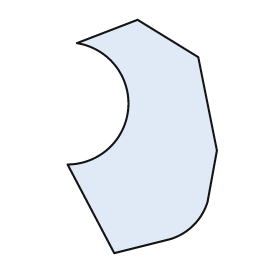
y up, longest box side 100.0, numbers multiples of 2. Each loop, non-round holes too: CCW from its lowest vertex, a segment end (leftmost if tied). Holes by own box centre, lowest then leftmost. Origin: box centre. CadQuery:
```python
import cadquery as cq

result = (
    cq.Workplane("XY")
    .moveTo(-12.0, -50.0)
    .lineTo(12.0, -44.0)
    .threePointArc((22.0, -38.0), (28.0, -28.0))
    .lineTo(32.0, -6.0)
    .lineTo(24.0, 34.0)
    .lineTo(-2.0, 50.0)
    .lineTo(-28.0, 40.0)
    .threePointArc((-6.0, 12.0), (-32.0, -12.0))
    .close()
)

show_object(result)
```